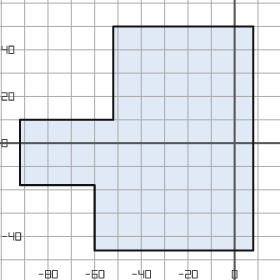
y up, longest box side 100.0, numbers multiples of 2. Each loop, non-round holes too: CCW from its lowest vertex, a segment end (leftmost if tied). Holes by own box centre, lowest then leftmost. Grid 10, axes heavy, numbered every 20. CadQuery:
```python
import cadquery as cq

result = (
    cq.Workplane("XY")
    .moveTo(-60.0, -46.0)
    .lineTo(8.0, -46.0)
    .lineTo(8.0, 50.0)
    .lineTo(-52.0, 50.0)
    .lineTo(-52.0, 10.0)
    .lineTo(-92.0, 10.0)
    .lineTo(-92.0, -18.0)
    .lineTo(-60.0, -18.0)
    .close()
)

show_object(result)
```